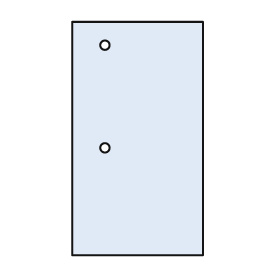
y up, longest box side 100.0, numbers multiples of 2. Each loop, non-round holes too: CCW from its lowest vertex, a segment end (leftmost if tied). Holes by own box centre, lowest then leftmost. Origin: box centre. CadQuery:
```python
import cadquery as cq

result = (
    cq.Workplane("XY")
    .moveTo(-28.0, -50.0)
    .lineTo(28.0, -50.0)
    .lineTo(28.0, 50.0)
    .lineTo(-28.0, 50.0)
    .close()
    .moveTo(-14.0, -4.0)
    .circle(2.0)
    .moveTo(-14.0, 40.0)
    .circle(2.0)
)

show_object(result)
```